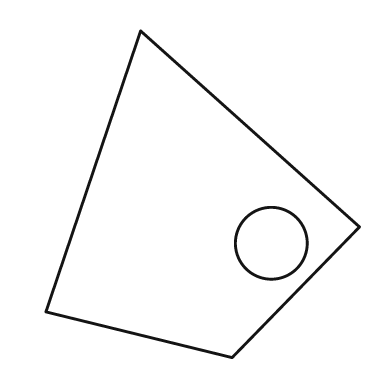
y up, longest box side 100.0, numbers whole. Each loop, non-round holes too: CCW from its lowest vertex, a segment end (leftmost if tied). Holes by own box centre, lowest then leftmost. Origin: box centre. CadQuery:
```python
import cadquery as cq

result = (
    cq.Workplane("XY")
    .moveTo(9.0, -50.0)
    .lineTo(48.0, -10.0)
    .lineTo(-19.0, 50.0)
    .lineTo(-48.0, -36.0)
    .close()
    .moveTo(21.0, -15.0)
    .circle(11.0)
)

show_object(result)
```